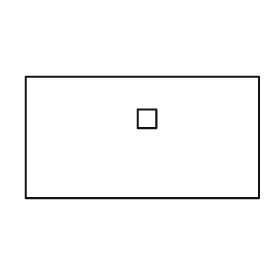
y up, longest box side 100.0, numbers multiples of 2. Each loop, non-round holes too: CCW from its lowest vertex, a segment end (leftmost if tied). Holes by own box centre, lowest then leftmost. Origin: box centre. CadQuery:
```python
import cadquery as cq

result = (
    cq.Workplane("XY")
    .moveTo(-50.0, -26.0)
    .lineTo(50.0, -26.0)
    .lineTo(50.0, 26.0)
    .lineTo(-50.0, 26.0)
    .close()
    .moveTo(-2.0, 4.0)
    .lineTo(6.0, 4.0)
    .lineTo(6.0, 12.0)
    .lineTo(-2.0, 12.0)
    .close()
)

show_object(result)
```